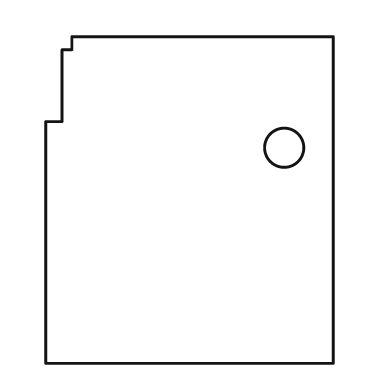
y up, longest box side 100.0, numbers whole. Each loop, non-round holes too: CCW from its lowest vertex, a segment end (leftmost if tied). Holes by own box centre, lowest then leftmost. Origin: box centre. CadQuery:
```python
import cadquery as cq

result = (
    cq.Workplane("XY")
    .moveTo(-44.0, -50.0)
    .lineTo(44.0, -50.0)
    .lineTo(44.0, 50.0)
    .lineTo(-36.0, 50.0)
    .lineTo(-36.0, 46.0)
    .lineTo(-39.0, 46.0)
    .lineTo(-39.0, 24.0)
    .lineTo(-44.0, 24.0)
    .close()
    .moveTo(29.0, 16.0)
    .circle(6.0)
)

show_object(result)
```